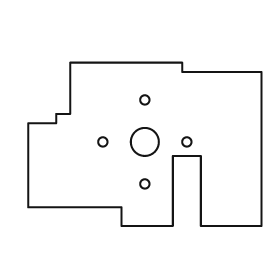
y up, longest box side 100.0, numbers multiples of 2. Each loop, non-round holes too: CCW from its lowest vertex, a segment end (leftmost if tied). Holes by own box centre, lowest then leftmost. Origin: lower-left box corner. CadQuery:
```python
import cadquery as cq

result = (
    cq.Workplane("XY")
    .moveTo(40.0, 0.0)
    .lineTo(62.0, 0.0)
    .lineTo(62.0, 30.0)
    .lineTo(74.0, 30.0)
    .lineTo(74.0, 0.0)
    .lineTo(100.0, 0.0)
    .lineTo(100.0, 66.0)
    .lineTo(66.0, 66.0)
    .lineTo(66.0, 70.0)
    .lineTo(18.0, 70.0)
    .lineTo(18.0, 48.0)
    .lineTo(12.0, 48.0)
    .lineTo(12.0, 44.0)
    .lineTo(0.0, 44.0)
    .lineTo(0.0, 8.0)
    .lineTo(40.0, 8.0)
    .close()
    .moveTo(50.0, 18.0)
    .circle(2.0)
    .moveTo(32.0, 36.0)
    .circle(2.0)
    .moveTo(50.0, 36.0)
    .circle(6.0)
    .moveTo(68.0, 36.0)
    .circle(2.0)
    .moveTo(50.0, 54.0)
    .circle(2.0)
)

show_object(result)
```